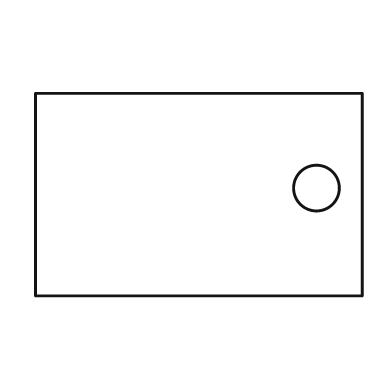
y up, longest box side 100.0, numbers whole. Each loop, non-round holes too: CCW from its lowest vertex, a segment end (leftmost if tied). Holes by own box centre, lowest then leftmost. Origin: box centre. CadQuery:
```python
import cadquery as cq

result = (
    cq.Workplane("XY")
    .moveTo(-50.0, -31.0)
    .lineTo(50.0, -31.0)
    .lineTo(50.0, 31.0)
    .lineTo(-50.0, 31.0)
    .close()
    .moveTo(36.0, 2.0)
    .circle(7.0)
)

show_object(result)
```